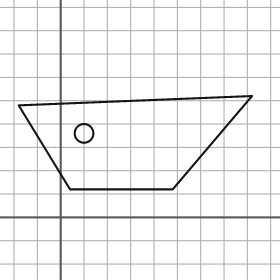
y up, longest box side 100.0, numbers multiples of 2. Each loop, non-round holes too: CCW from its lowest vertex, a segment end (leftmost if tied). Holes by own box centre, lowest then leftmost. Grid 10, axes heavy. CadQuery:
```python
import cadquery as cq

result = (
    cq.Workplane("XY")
    .moveTo(4.0, 12.0)
    .lineTo(48.0, 12.0)
    .lineTo(82.0, 52.0)
    .lineTo(-18.0, 48.0)
    .close()
    .moveTo(10.0, 36.0)
    .circle(4.0)
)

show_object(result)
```